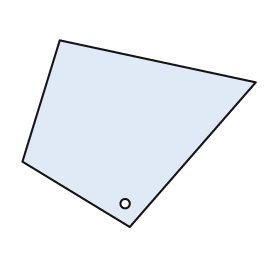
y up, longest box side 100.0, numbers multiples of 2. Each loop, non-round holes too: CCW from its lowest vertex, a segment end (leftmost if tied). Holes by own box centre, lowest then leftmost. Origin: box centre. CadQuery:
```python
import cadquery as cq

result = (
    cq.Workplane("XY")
    .moveTo(-4.0, -40.0)
    .lineTo(50.0, 22.0)
    .lineTo(-34.0, 40.0)
    .lineTo(-50.0, -12.0)
    .close()
    .moveTo(-6.0, -30.0)
    .circle(2.0)
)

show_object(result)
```